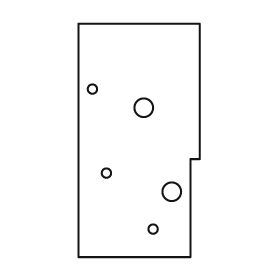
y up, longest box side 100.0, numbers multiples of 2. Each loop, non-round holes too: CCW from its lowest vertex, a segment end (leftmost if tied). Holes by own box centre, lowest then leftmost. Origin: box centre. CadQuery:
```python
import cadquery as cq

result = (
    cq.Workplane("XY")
    .moveTo(-26.0, -50.0)
    .lineTo(22.0, -50.0)
    .lineTo(22.0, -8.0)
    .lineTo(26.0, -8.0)
    .lineTo(26.0, 50.0)
    .lineTo(-26.0, 50.0)
    .close()
    .moveTo(6.0, -38.0)
    .circle(2.0)
    .moveTo(14.0, -22.0)
    .circle(4.0)
    .moveTo(-14.0, -14.0)
    .circle(2.0)
    .moveTo(2.0, 14.0)
    .circle(4.0)
    .moveTo(-20.0, 22.0)
    .circle(2.0)
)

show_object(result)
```